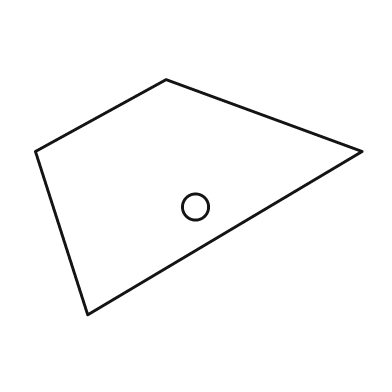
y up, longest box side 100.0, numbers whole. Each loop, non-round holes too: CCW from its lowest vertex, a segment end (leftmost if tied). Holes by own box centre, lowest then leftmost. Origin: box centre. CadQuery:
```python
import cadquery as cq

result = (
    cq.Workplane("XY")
    .moveTo(-34.0, -36.0)
    .lineTo(50.0, 14.0)
    .lineTo(-10.0, 36.0)
    .lineTo(-50.0, 14.0)
    .close()
    .moveTo(-1.0, -3.0)
    .circle(4.0)
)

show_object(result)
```